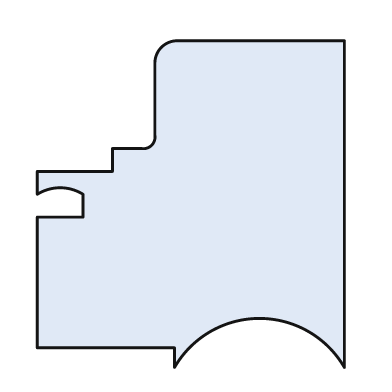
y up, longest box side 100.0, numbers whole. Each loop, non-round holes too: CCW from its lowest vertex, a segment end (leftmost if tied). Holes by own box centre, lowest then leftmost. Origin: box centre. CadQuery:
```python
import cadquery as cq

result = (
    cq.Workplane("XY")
    .moveTo(-5.0, -50.0)
    .threePointArc((21.0, -35.0), (47.0, -50.0))
    .lineTo(47.0, 50.0)
    .lineTo(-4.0, 50.0)
    .threePointArc((-9.0, 48.0), (-11.0, 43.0))
    .lineTo(-11.0, 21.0)
    .threePointArc((-12.0, 18.0), (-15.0, 17.0))
    .lineTo(-24.0, 17.0)
    .lineTo(-24.0, 10.0)
    .lineTo(-47.0, 10.0)
    .lineTo(-47.0, 3.0)
    .threePointArc((-40.0, 5.0), (-33.0, 3.0))
    .lineTo(-33.0, -4.0)
    .lineTo(-47.0, -4.0)
    .lineTo(-47.0, -44.0)
    .lineTo(-5.0, -44.0)
    .close()
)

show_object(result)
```